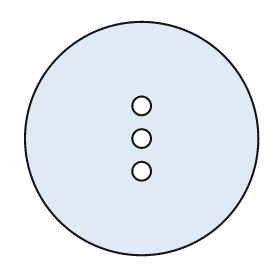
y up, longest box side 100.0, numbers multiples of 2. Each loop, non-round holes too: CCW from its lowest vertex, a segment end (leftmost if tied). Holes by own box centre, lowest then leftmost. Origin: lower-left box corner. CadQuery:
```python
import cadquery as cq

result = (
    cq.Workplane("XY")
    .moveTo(50.0, 50.0)
    .circle(50.0)
    .moveTo(50.0, 36.0)
    .circle(4.0)
    .moveTo(50.0, 50.0)
    .circle(4.0)
    .moveTo(50.0, 64.0)
    .circle(4.0)
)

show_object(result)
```